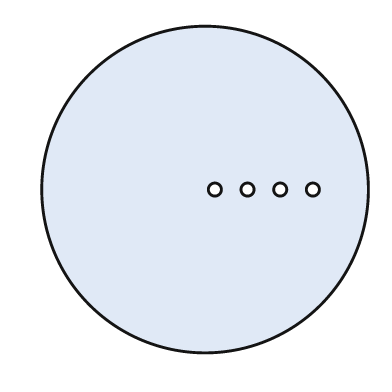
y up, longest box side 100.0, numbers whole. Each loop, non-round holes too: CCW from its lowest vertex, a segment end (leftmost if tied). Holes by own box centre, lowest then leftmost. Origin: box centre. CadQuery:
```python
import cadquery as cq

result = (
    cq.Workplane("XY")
    .moveTo(0.0, 0.0)
    .circle(50.0)
    .moveTo(3.0, 0.0)
    .circle(2.0)
    .moveTo(13.0, 0.0)
    .circle(2.0)
    .moveTo(23.0, 0.0)
    .circle(2.0)
    .moveTo(33.0, 0.0)
    .circle(2.0)
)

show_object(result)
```